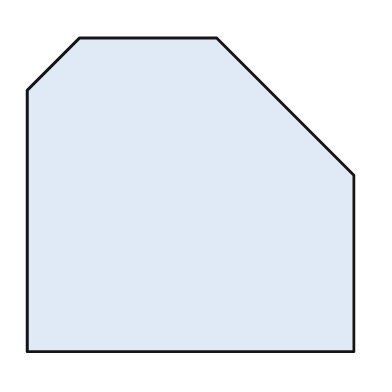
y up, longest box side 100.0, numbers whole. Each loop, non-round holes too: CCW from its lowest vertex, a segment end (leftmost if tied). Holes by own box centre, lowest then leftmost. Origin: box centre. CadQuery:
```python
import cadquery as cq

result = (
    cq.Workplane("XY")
    .moveTo(-50.0, -48.0)
    .lineTo(50.0, -48.0)
    .lineTo(50.0, 6.0)
    .lineTo(8.0, 48.0)
    .lineTo(-34.0, 48.0)
    .lineTo(-50.0, 32.0)
    .close()
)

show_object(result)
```